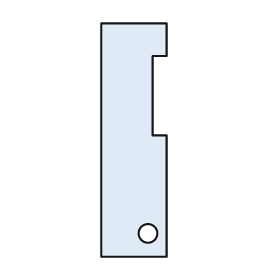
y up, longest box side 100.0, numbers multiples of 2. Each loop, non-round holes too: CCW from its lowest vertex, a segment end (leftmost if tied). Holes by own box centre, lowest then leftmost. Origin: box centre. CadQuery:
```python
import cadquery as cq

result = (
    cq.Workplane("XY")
    .moveTo(-14.0, -50.0)
    .lineTo(14.0, -50.0)
    .lineTo(14.0, 2.0)
    .lineTo(8.0, 2.0)
    .lineTo(8.0, 36.0)
    .lineTo(14.0, 36.0)
    .lineTo(14.0, 50.0)
    .lineTo(-14.0, 50.0)
    .close()
    .moveTo(6.0, -40.0)
    .circle(4.0)
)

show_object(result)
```